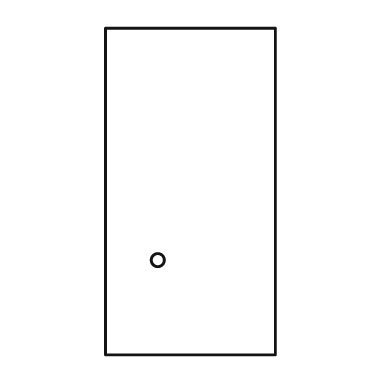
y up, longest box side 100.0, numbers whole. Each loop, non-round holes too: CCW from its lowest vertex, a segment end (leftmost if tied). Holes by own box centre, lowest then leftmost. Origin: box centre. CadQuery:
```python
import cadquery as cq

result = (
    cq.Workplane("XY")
    .moveTo(-26.0, -50.0)
    .lineTo(26.0, -50.0)
    .lineTo(26.0, 50.0)
    .lineTo(-26.0, 50.0)
    .close()
    .moveTo(-10.0, -21.0)
    .circle(2.0)
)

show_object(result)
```